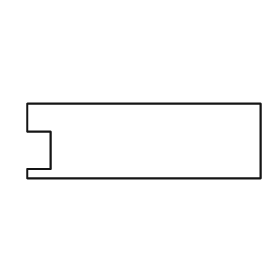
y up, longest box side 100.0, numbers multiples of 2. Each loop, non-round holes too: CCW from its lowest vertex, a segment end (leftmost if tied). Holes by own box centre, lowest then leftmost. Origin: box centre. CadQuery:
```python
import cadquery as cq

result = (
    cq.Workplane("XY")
    .moveTo(-50.0, -16.0)
    .lineTo(50.0, -16.0)
    .lineTo(50.0, 16.0)
    .lineTo(-50.0, 16.0)
    .lineTo(-50.0, 4.0)
    .lineTo(-40.0, 4.0)
    .lineTo(-40.0, -12.0)
    .lineTo(-50.0, -12.0)
    .close()
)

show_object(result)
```